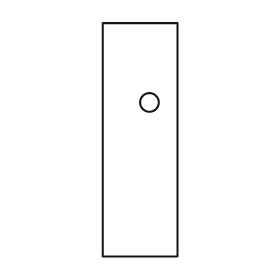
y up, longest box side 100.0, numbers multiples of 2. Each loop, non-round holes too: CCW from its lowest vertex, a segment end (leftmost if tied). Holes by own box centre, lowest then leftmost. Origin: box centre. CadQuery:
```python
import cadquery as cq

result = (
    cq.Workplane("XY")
    .moveTo(-16.0, -50.0)
    .lineTo(16.0, -50.0)
    .lineTo(16.0, 50.0)
    .lineTo(-16.0, 50.0)
    .close()
    .moveTo(4.0, 16.0)
    .circle(4.0)
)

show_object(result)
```